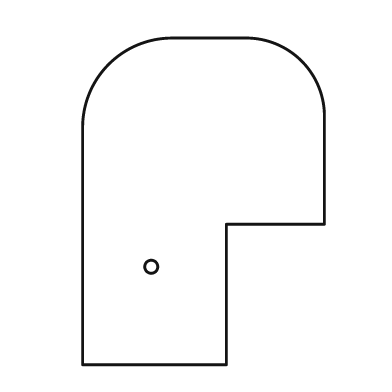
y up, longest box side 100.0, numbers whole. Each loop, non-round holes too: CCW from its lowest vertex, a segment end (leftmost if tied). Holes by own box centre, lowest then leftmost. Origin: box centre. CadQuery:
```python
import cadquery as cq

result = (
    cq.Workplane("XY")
    .moveTo(-37.0, -50.0)
    .lineTo(7.0, -50.0)
    .lineTo(7.0, -7.0)
    .lineTo(37.0, -7.0)
    .lineTo(37.0, 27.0)
    .threePointArc((30.0, 43.0), (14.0, 50.0))
    .lineTo(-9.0, 50.0)
    .threePointArc((-29.0, 42.0), (-37.0, 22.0))
    .close()
    .moveTo(-16.0, -20.0)
    .circle(2.0)
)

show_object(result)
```